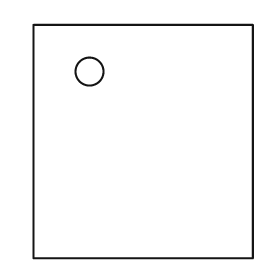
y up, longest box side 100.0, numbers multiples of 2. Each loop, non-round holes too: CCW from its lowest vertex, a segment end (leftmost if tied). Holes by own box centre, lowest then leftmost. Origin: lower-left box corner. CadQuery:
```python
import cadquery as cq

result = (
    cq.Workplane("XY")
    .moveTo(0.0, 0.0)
    .lineTo(94.0, 0.0)
    .lineTo(94.0, 100.0)
    .lineTo(0.0, 100.0)
    .close()
    .moveTo(24.0, 80.0)
    .circle(6.0)
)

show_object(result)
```